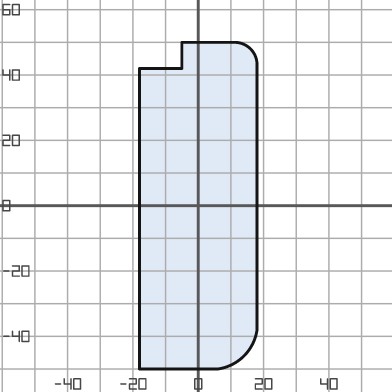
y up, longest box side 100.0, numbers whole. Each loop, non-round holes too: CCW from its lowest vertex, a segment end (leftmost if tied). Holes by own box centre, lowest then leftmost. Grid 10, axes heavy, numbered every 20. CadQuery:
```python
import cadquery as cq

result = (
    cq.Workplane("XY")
    .moveTo(-18.0, -50.0)
    .lineTo(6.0, -50.0)
    .threePointArc((14.0, -46.0), (18.0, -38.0))
    .lineTo(18.0, 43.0)
    .threePointArc((16.0, 48.0), (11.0, 50.0))
    .lineTo(-5.0, 50.0)
    .lineTo(-5.0, 42.0)
    .lineTo(-18.0, 42.0)
    .close()
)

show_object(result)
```